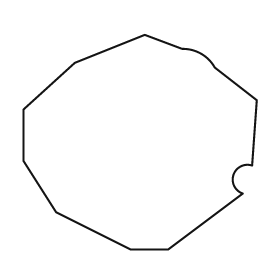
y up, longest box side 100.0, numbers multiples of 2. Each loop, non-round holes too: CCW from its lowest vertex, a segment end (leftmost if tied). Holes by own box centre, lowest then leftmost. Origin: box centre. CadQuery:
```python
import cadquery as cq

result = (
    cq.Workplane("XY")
    .moveTo(-4.0, -46.0)
    .lineTo(12.0, -46.0)
    .lineTo(44.0, -22.0)
    .threePointArc((40.0, -14.0), (48.0, -10.0))
    .lineTo(50.0, 18.0)
    .lineTo(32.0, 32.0)
    .threePointArc((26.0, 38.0), (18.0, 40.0))
    .lineTo(2.0, 46.0)
    .lineTo(-28.0, 34.0)
    .lineTo(-50.0, 14.0)
    .lineTo(-50.0, -8.0)
    .lineTo(-36.0, -30.0)
    .close()
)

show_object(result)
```